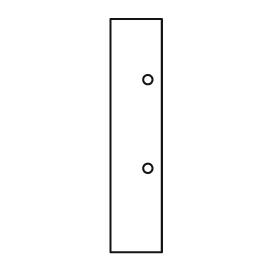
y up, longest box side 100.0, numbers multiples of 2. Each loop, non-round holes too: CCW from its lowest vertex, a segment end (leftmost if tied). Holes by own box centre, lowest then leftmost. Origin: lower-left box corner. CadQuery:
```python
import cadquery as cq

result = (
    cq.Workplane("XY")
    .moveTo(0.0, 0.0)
    .lineTo(22.0, 0.0)
    .lineTo(22.0, 100.0)
    .lineTo(0.0, 100.0)
    .close()
    .moveTo(16.0, 36.0)
    .circle(2.0)
    .moveTo(16.0, 74.0)
    .circle(2.0)
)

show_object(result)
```